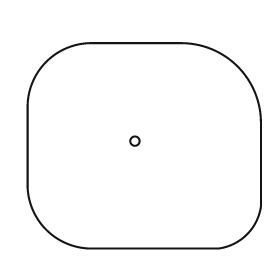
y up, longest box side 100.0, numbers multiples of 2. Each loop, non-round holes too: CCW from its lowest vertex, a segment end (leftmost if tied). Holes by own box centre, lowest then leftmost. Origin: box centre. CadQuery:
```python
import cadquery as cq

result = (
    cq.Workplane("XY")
    .moveTo(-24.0, -44.0)
    .lineTo(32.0, -44.0)
    .threePointArc((44.0, -38.0), (50.0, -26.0))
    .lineTo(50.0, 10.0)
    .threePointArc((40.0, 34.0), (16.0, 44.0))
    .lineTo(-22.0, 44.0)
    .threePointArc((-42.0, 36.0), (-50.0, 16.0))
    .lineTo(-50.0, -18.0)
    .threePointArc((-42.0, -36.0), (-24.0, -44.0))
    .close()
    .moveTo(-4.0, 2.0)
    .circle(2.0)
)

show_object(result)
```